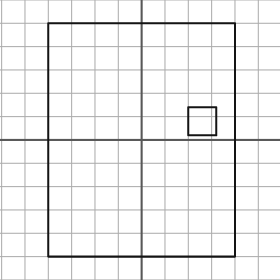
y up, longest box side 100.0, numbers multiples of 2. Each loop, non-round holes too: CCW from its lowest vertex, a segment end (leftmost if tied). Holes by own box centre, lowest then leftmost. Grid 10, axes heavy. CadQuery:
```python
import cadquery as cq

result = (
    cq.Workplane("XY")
    .moveTo(-40.0, -50.0)
    .lineTo(40.0, -50.0)
    .lineTo(40.0, 50.0)
    .lineTo(-40.0, 50.0)
    .close()
    .moveTo(20.0, 2.0)
    .lineTo(32.0, 2.0)
    .lineTo(32.0, 14.0)
    .lineTo(20.0, 14.0)
    .close()
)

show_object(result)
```